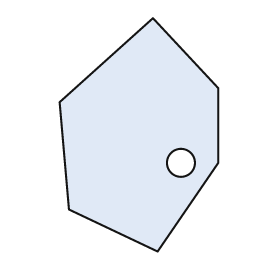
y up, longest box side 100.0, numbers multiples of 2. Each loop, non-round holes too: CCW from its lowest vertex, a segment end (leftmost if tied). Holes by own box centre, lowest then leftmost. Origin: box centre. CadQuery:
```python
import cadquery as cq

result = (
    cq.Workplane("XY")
    .moveTo(8.0, -50.0)
    .lineTo(34.0, -12.0)
    .lineTo(34.0, 20.0)
    .lineTo(6.0, 50.0)
    .lineTo(-34.0, 14.0)
    .lineTo(-30.0, -32.0)
    .close()
    .moveTo(18.0, -12.0)
    .circle(6.0)
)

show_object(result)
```